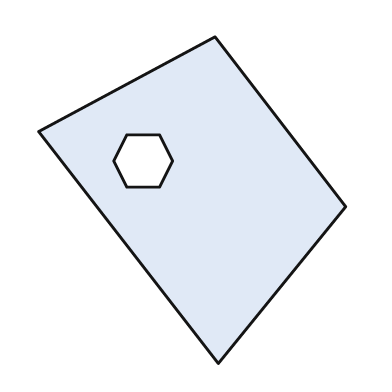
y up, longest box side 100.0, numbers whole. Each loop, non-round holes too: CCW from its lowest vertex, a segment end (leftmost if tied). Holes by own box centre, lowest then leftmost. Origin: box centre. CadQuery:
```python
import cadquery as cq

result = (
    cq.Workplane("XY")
    .moveTo(8.0, -50.0)
    .lineTo(47.0, -2.0)
    .lineTo(7.0, 50.0)
    .lineTo(-47.0, 21.0)
    .close()
    .moveTo(-20.0, 4.0)
    .lineTo(-10.0, 4.0)
    .lineTo(-6.0, 12.0)
    .lineTo(-10.0, 20.0)
    .lineTo(-20.0, 20.0)
    .lineTo(-24.0, 12.0)
    .close()
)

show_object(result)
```